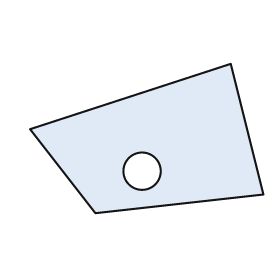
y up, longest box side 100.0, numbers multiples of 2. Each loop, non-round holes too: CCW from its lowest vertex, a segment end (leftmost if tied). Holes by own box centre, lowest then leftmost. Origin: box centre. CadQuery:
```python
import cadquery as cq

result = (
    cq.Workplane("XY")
    .moveTo(-22.0, -32.0)
    .lineTo(50.0, -24.0)
    .lineTo(36.0, 32.0)
    .lineTo(-50.0, 4.0)
    .close()
    .moveTo(-2.0, -14.0)
    .circle(8.0)
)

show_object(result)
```